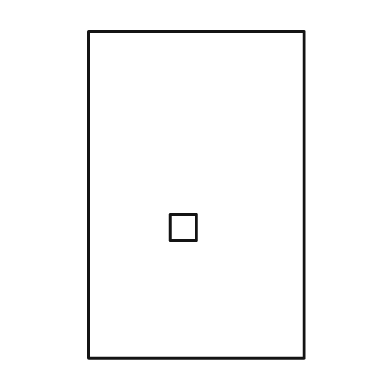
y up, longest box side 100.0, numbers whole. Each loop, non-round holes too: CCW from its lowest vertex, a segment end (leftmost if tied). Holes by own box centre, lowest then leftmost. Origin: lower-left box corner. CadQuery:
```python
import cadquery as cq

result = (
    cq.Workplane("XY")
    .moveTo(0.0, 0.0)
    .lineTo(66.0, 0.0)
    .lineTo(66.0, 100.0)
    .lineTo(0.0, 100.0)
    .close()
    .moveTo(25.0, 36.0)
    .lineTo(33.0, 36.0)
    .lineTo(33.0, 44.0)
    .lineTo(25.0, 44.0)
    .close()
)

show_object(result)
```